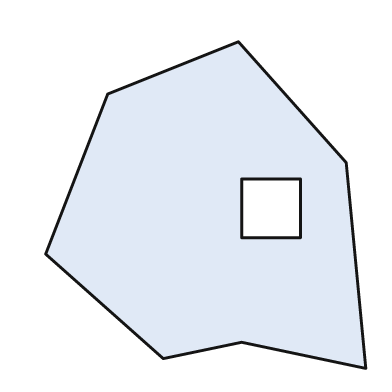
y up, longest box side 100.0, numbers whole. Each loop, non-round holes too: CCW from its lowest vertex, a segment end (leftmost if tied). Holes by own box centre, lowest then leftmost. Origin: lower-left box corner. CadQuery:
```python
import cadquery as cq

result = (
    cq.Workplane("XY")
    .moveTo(98.0, 0.0)
    .lineTo(92.0, 63.0)
    .lineTo(59.0, 100.0)
    .lineTo(19.0, 84.0)
    .lineTo(0.0, 35.0)
    .lineTo(36.0, 3.0)
    .lineTo(60.0, 8.0)
    .close()
    .moveTo(60.0, 40.0)
    .lineTo(78.0, 40.0)
    .lineTo(78.0, 58.0)
    .lineTo(60.0, 58.0)
    .close()
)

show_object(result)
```